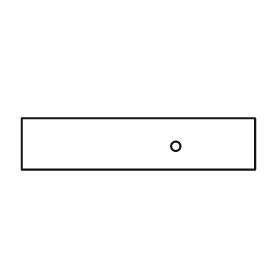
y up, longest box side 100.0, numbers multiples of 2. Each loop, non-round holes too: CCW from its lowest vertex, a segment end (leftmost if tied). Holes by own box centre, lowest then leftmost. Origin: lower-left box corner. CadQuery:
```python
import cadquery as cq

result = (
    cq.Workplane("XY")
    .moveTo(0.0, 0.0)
    .lineTo(100.0, 0.0)
    .lineTo(100.0, 22.0)
    .lineTo(0.0, 22.0)
    .close()
    .moveTo(66.0, 10.0)
    .circle(2.0)
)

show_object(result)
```